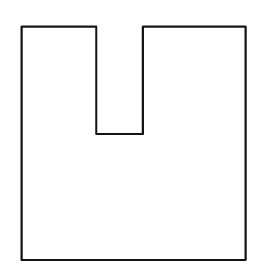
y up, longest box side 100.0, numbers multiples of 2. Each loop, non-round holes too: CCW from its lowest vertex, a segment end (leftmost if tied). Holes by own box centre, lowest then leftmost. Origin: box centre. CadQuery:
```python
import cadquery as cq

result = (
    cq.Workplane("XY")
    .moveTo(-48.0, -50.0)
    .lineTo(48.0, -50.0)
    .lineTo(48.0, 50.0)
    .lineTo(4.0, 50.0)
    .lineTo(4.0, 4.0)
    .lineTo(-16.0, 4.0)
    .lineTo(-16.0, 50.0)
    .lineTo(-48.0, 50.0)
    .close()
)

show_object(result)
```